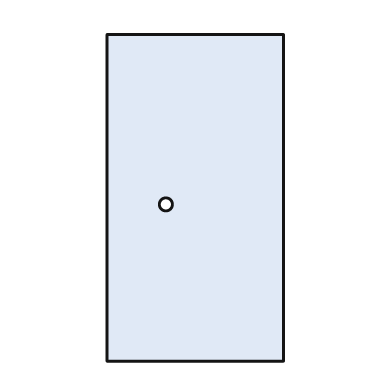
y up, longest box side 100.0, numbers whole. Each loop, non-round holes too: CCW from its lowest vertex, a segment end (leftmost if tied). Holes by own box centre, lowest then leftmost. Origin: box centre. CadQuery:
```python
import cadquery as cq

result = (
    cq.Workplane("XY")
    .moveTo(-27.0, -50.0)
    .lineTo(27.0, -50.0)
    .lineTo(27.0, 50.0)
    .lineTo(-27.0, 50.0)
    .close()
    .moveTo(-9.0, -2.0)
    .circle(2.0)
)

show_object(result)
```